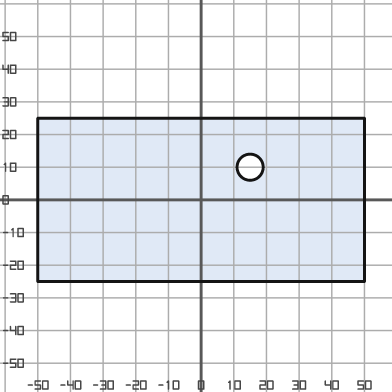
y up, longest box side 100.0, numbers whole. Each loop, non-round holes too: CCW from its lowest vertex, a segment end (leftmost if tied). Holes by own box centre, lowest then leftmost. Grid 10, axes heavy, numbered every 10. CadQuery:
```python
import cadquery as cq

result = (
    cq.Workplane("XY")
    .moveTo(-50.0, -25.0)
    .lineTo(50.0, -25.0)
    .lineTo(50.0, 25.0)
    .lineTo(-50.0, 25.0)
    .close()
    .moveTo(15.0, 10.0)
    .circle(4.0)
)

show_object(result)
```